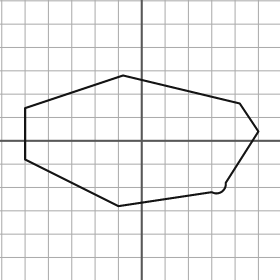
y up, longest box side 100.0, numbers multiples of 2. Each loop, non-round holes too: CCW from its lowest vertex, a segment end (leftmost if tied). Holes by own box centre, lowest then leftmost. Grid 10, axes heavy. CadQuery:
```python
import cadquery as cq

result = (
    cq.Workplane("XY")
    .moveTo(-10.0, -28.0)
    .lineTo(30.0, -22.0)
    .threePointArc((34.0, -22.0), (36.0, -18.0))
    .lineTo(50.0, 4.0)
    .lineTo(42.0, 16.0)
    .lineTo(-8.0, 28.0)
    .lineTo(-50.0, 14.0)
    .lineTo(-50.0, -8.0)
    .close()
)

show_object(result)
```